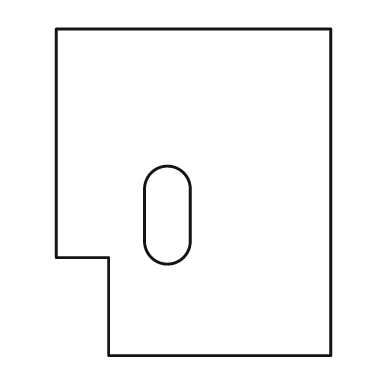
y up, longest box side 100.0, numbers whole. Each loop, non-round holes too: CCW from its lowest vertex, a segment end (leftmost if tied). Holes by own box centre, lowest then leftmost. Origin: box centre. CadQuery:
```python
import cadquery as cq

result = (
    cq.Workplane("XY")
    .moveTo(-26.0, -50.0)
    .lineTo(42.0, -50.0)
    .lineTo(42.0, 50.0)
    .lineTo(-42.0, 50.0)
    .lineTo(-42.0, -20.0)
    .lineTo(-26.0, -20.0)
    .close()
    .moveTo(-15.0, -15.0)
    .threePointArc((-8.0, -22.0), (-1.0, -15.0))
    .lineTo(-1.0, 1.0)
    .threePointArc((-8.0, 8.0), (-15.0, 1.0))
    .close()
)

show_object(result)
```